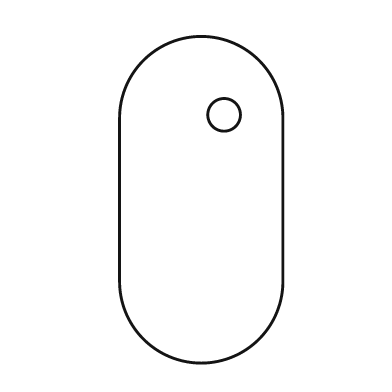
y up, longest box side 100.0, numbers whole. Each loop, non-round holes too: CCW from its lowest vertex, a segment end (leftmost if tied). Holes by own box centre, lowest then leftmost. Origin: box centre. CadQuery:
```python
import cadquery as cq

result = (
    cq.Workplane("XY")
    .moveTo(-25.0, -25.0)
    .threePointArc((0.0, -50.0), (25.0, -25.0))
    .lineTo(25.0, 25.0)
    .threePointArc((0.0, 50.0), (-25.0, 25.0))
    .close()
    .moveTo(7.0, 26.0)
    .circle(5.0)
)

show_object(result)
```